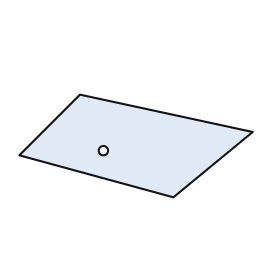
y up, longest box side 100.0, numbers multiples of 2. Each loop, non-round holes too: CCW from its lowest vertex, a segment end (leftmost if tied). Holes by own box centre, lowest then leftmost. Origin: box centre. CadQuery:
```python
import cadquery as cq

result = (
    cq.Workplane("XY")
    .moveTo(16.0, -22.0)
    .lineTo(50.0, 6.0)
    .lineTo(-24.0, 22.0)
    .lineTo(-50.0, -4.0)
    .close()
    .moveTo(-14.0, -2.0)
    .circle(2.0)
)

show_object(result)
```